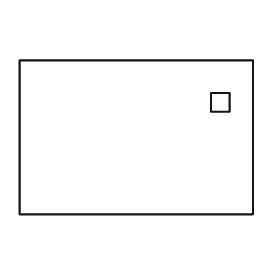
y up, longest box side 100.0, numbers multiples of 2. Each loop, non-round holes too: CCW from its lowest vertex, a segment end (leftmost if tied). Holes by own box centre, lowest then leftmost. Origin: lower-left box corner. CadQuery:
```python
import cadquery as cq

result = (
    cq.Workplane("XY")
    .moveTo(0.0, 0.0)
    .lineTo(100.0, 0.0)
    .lineTo(100.0, 66.0)
    .lineTo(0.0, 66.0)
    .close()
    .moveTo(82.0, 44.0)
    .lineTo(90.0, 44.0)
    .lineTo(90.0, 52.0)
    .lineTo(82.0, 52.0)
    .close()
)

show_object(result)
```